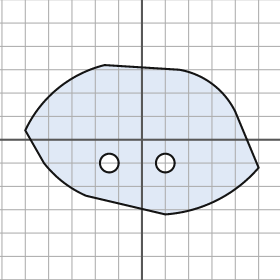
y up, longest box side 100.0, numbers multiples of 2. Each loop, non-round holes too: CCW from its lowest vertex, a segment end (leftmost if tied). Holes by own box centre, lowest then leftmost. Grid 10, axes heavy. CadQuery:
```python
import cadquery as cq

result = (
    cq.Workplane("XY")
    .moveTo(10.0, -32.0)
    .threePointArc((32.0, -26.0), (50.0, -12.0))
    .lineTo(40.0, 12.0)
    .threePointArc((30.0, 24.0), (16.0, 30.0))
    .lineTo(-16.0, 32.0)
    .threePointArc((-36.0, 22.0), (-50.0, 4.0))
    .lineTo(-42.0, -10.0)
    .threePointArc((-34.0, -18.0), (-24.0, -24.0))
    .close()
    .moveTo(-14.0, -10.0)
    .circle(4.0)
    .moveTo(10.0, -10.0)
    .circle(4.0)
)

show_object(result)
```